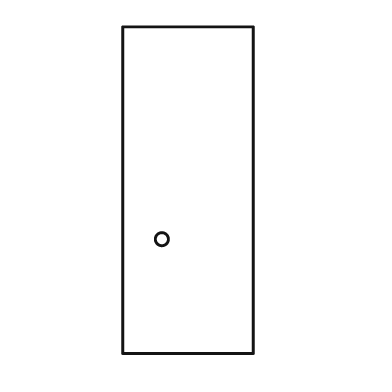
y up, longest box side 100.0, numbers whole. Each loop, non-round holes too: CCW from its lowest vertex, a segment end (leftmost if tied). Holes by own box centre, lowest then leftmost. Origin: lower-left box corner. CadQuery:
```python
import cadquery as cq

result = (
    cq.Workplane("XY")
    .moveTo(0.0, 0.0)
    .lineTo(40.0, 0.0)
    .lineTo(40.0, 100.0)
    .lineTo(0.0, 100.0)
    .close()
    .moveTo(12.0, 35.0)
    .circle(2.0)
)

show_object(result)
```